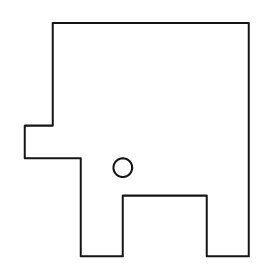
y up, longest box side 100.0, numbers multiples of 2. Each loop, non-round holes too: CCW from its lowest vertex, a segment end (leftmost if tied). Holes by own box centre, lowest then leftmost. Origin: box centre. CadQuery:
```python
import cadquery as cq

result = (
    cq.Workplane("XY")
    .moveTo(-24.0, -50.0)
    .lineTo(-6.0, -50.0)
    .lineTo(-6.0, -24.0)
    .lineTo(30.0, -24.0)
    .lineTo(30.0, -50.0)
    .lineTo(48.0, -50.0)
    .lineTo(48.0, 50.0)
    .lineTo(-36.0, 50.0)
    .lineTo(-36.0, 6.0)
    .lineTo(-48.0, 6.0)
    .lineTo(-48.0, -8.0)
    .lineTo(-24.0, -8.0)
    .close()
    .moveTo(-6.0, -12.0)
    .circle(4.0)
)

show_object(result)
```